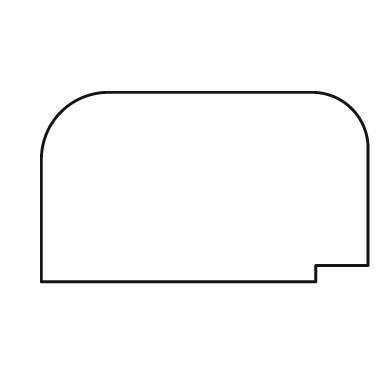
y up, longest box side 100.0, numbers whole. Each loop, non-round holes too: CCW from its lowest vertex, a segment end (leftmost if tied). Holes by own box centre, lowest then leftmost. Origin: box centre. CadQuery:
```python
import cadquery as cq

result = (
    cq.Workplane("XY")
    .moveTo(-50.0, -29.0)
    .lineTo(34.0, -29.0)
    .lineTo(34.0, -24.0)
    .lineTo(50.0, -24.0)
    .lineTo(50.0, 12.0)
    .threePointArc((45.0, 24.0), (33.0, 29.0))
    .lineTo(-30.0, 29.0)
    .threePointArc((-44.0, 23.0), (-50.0, 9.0))
    .close()
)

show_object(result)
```